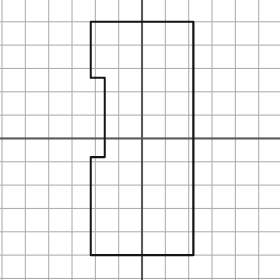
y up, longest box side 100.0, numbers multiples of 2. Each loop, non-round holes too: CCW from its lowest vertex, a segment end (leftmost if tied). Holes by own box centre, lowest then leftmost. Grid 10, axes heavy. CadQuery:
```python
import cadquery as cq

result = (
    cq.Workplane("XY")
    .moveTo(-22.0, -50.0)
    .lineTo(22.0, -50.0)
    .lineTo(22.0, 50.0)
    .lineTo(-22.0, 50.0)
    .lineTo(-22.0, 26.0)
    .lineTo(-16.0, 26.0)
    .lineTo(-16.0, -8.0)
    .lineTo(-22.0, -8.0)
    .close()
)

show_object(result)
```